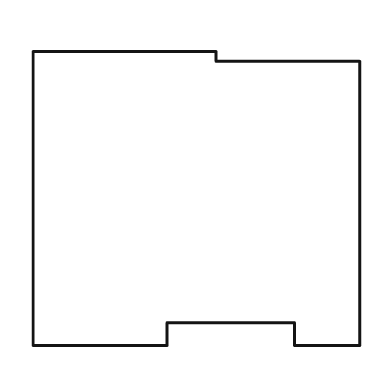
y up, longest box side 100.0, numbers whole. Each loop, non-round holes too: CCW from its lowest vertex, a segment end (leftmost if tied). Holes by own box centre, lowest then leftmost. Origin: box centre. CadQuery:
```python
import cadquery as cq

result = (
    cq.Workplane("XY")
    .moveTo(-50.0, -45.0)
    .lineTo(-9.0, -45.0)
    .lineTo(-9.0, -38.0)
    .lineTo(30.0, -38.0)
    .lineTo(30.0, -45.0)
    .lineTo(50.0, -45.0)
    .lineTo(50.0, 42.0)
    .lineTo(6.0, 42.0)
    .lineTo(6.0, 45.0)
    .lineTo(-50.0, 45.0)
    .close()
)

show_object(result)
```